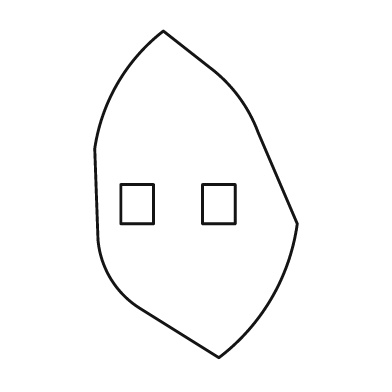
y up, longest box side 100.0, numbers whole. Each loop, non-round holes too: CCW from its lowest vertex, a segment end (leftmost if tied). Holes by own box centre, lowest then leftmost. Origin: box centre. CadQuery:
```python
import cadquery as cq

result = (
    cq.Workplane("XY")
    .moveTo(7.0, -50.0)
    .threePointArc((23.0, -32.0), (31.0, -9.0))
    .lineTo(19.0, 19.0)
    .threePointArc((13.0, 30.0), (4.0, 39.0))
    .lineTo(-10.0, 50.0)
    .threePointArc((-24.0, 34.0), (-31.0, 14.0))
    .lineTo(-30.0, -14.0)
    .threePointArc((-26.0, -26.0), (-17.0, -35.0))
    .close()
    .moveTo(-23.0, -9.0)
    .lineTo(-13.0, -9.0)
    .lineTo(-13.0, 3.0)
    .lineTo(-23.0, 3.0)
    .close()
    .moveTo(2.0, -9.0)
    .lineTo(12.0, -9.0)
    .lineTo(12.0, 3.0)
    .lineTo(2.0, 3.0)
    .close()
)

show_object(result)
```